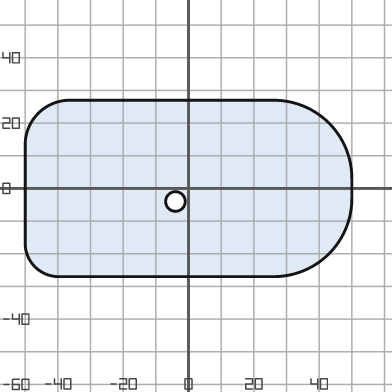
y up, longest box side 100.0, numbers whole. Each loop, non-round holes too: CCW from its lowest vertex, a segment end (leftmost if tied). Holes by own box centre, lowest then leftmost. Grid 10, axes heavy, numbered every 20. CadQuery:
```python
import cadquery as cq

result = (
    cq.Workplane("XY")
    .moveTo(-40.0, -27.0)
    .lineTo(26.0, -27.0)
    .threePointArc((43.0, -20.0), (50.0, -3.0))
    .lineTo(50.0, 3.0)
    .threePointArc((43.0, 20.0), (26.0, 27.0))
    .lineTo(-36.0, 27.0)
    .threePointArc((-46.0, 23.0), (-50.0, 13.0))
    .lineTo(-50.0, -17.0)
    .threePointArc((-47.0, -24.0), (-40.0, -27.0))
    .close()
    .moveTo(-4.0, -4.0)
    .circle(3.0)
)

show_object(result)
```